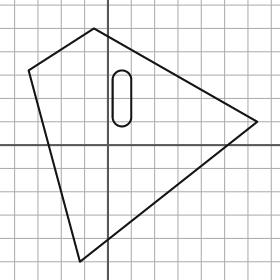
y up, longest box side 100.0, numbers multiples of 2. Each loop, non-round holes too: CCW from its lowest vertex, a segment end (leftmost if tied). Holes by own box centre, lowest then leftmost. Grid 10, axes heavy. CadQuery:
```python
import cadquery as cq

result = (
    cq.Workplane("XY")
    .moveTo(-12.0, -50.0)
    .lineTo(64.0, 10.0)
    .lineTo(-6.0, 50.0)
    .lineTo(-34.0, 32.0)
    .close()
    .moveTo(2.0, 12.0)
    .threePointArc((6.0, 8.0), (10.0, 12.0))
    .lineTo(10.0, 28.0)
    .threePointArc((6.0, 32.0), (2.0, 28.0))
    .close()
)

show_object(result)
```